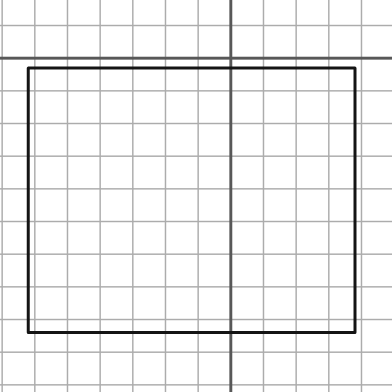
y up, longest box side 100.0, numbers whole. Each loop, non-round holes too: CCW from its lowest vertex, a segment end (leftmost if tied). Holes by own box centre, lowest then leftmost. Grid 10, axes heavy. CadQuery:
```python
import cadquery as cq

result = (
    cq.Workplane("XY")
    .moveTo(-62.0, -84.0)
    .lineTo(38.0, -84.0)
    .lineTo(38.0, -3.0)
    .lineTo(-62.0, -3.0)
    .close()
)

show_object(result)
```